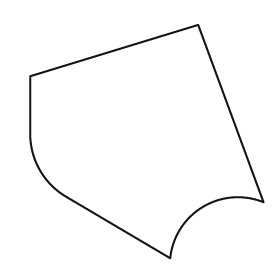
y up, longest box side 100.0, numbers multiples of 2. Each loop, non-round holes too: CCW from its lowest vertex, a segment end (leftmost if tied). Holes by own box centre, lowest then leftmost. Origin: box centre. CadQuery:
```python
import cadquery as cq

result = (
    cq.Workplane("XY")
    .moveTo(10.0, -50.0)
    .threePointArc((24.0, -28.0), (50.0, -26.0))
    .lineTo(22.0, 50.0)
    .lineTo(-50.0, 28.0)
    .lineTo(-50.0, 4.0)
    .threePointArc((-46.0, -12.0), (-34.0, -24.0))
    .close()
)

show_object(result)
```